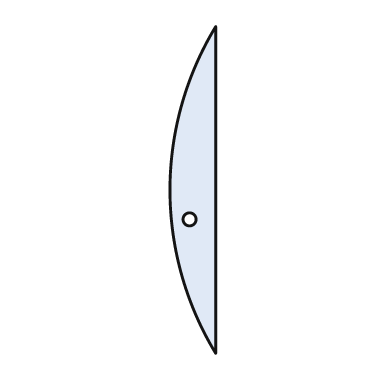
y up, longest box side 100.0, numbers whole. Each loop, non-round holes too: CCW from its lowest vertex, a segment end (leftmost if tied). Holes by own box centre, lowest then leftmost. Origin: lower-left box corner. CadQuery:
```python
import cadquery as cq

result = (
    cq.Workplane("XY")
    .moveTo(14.0, 0.0)
    .lineTo(14.0, 100.0)
    .threePointArc((0.0, 50.0), (14.0, 0.0))
    .close()
    .moveTo(6.0, 41.0)
    .circle(2.0)
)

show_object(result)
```